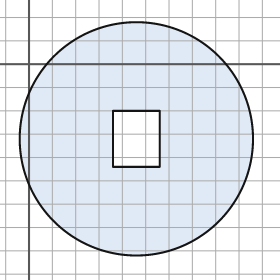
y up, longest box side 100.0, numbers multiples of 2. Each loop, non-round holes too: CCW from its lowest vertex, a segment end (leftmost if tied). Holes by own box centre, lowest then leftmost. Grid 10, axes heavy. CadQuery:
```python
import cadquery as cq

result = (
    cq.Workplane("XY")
    .moveTo(46.0, -32.0)
    .circle(50.0)
    .moveTo(36.0, -44.0)
    .lineTo(56.0, -44.0)
    .lineTo(56.0, -20.0)
    .lineTo(36.0, -20.0)
    .close()
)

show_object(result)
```